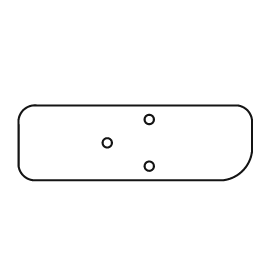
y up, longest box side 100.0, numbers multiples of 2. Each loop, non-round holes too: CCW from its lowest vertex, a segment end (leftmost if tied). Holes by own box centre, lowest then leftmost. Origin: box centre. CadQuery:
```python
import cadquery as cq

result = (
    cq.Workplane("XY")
    .moveTo(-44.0, -16.0)
    .lineTo(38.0, -16.0)
    .threePointArc((46.0, -12.0), (50.0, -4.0))
    .lineTo(50.0, 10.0)
    .threePointArc((48.0, 14.0), (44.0, 16.0))
    .lineTo(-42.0, 16.0)
    .threePointArc((-48.0, 14.0), (-50.0, 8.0))
    .lineTo(-50.0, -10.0)
    .threePointArc((-48.0, -14.0), (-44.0, -16.0))
    .close()
    .moveTo(6.0, -10.0)
    .circle(2.0)
    .moveTo(-12.0, 0.0)
    .circle(2.0)
    .moveTo(6.0, 10.0)
    .circle(2.0)
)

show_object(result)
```